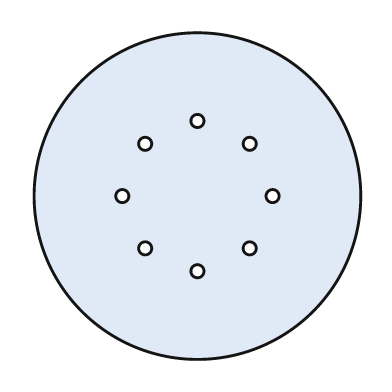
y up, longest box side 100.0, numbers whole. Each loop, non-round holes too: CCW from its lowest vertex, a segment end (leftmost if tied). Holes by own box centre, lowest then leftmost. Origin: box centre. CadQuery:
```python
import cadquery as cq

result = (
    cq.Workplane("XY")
    .moveTo(0.0, 0.0)
    .circle(50.0)
    .moveTo(0.0, -23.0)
    .circle(2.0)
    .moveTo(-16.0, -16.0)
    .circle(2.0)
    .moveTo(16.0, -16.0)
    .circle(2.0)
    .moveTo(-23.0, 0.0)
    .circle(2.0)
    .moveTo(23.0, 0.0)
    .circle(2.0)
    .moveTo(-16.0, 16.0)
    .circle(2.0)
    .moveTo(16.0, 16.0)
    .circle(2.0)
    .moveTo(0.0, 23.0)
    .circle(2.0)
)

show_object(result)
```